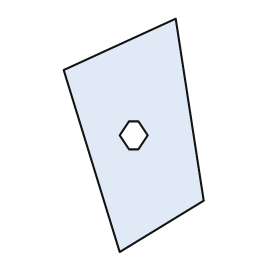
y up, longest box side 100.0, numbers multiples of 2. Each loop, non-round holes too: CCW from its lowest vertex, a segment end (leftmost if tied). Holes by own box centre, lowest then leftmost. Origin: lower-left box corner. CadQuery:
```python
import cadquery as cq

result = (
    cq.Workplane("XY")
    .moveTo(24.0, 0.0)
    .lineTo(60.0, 22.0)
    .lineTo(48.0, 100.0)
    .lineTo(0.0, 78.0)
    .close()
    .moveTo(28.0, 44.0)
    .lineTo(32.0, 44.0)
    .lineTo(36.0, 50.0)
    .lineTo(32.0, 56.0)
    .lineTo(28.0, 56.0)
    .lineTo(24.0, 50.0)
    .close()
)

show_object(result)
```